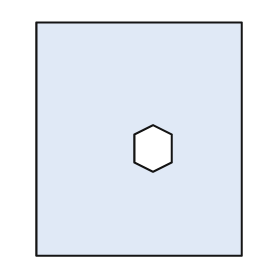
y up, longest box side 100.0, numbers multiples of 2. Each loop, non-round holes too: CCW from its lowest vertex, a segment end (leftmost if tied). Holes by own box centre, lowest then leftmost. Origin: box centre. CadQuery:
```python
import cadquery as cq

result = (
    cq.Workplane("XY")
    .moveTo(-44.0, -50.0)
    .lineTo(44.0, -50.0)
    .lineTo(44.0, 50.0)
    .lineTo(-44.0, 50.0)
    .close()
    .moveTo(6.0, -14.0)
    .lineTo(14.0, -10.0)
    .lineTo(14.0, 2.0)
    .lineTo(6.0, 6.0)
    .lineTo(-2.0, 2.0)
    .lineTo(-2.0, -10.0)
    .close()
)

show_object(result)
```